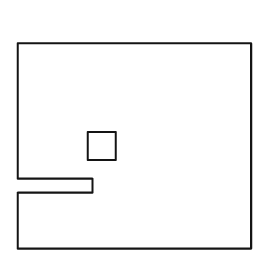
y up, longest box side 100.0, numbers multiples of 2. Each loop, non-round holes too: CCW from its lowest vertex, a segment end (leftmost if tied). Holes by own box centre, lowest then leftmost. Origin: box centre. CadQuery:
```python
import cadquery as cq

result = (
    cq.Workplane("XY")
    .moveTo(-50.0, -44.0)
    .lineTo(50.0, -44.0)
    .lineTo(50.0, 44.0)
    .lineTo(-50.0, 44.0)
    .lineTo(-50.0, -14.0)
    .lineTo(-18.0, -14.0)
    .lineTo(-18.0, -20.0)
    .lineTo(-50.0, -20.0)
    .close()
    .moveTo(-20.0, -6.0)
    .lineTo(-8.0, -6.0)
    .lineTo(-8.0, 6.0)
    .lineTo(-20.0, 6.0)
    .close()
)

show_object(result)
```